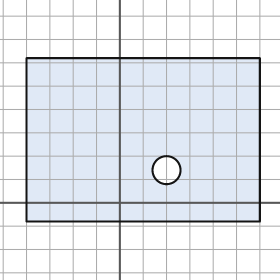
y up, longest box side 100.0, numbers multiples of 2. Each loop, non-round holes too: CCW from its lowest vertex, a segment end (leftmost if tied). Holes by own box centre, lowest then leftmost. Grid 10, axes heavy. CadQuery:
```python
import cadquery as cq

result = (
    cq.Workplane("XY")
    .moveTo(-40.0, -8.0)
    .lineTo(60.0, -8.0)
    .lineTo(60.0, 62.0)
    .lineTo(-40.0, 62.0)
    .close()
    .moveTo(20.0, 14.0)
    .circle(6.0)
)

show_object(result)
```